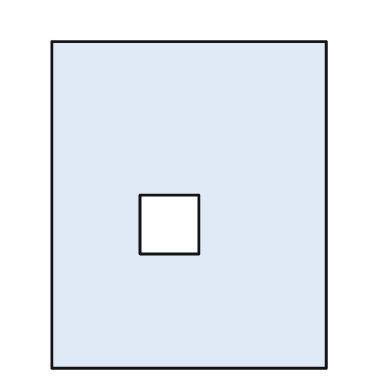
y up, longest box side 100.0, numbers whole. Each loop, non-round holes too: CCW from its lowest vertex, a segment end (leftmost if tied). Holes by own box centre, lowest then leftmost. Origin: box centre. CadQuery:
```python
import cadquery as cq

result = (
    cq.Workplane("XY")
    .moveTo(-42.0, -50.0)
    .lineTo(42.0, -50.0)
    .lineTo(42.0, 50.0)
    .lineTo(-42.0, 50.0)
    .close()
    .moveTo(-15.0, -15.0)
    .lineTo(3.0, -15.0)
    .lineTo(3.0, 3.0)
    .lineTo(-15.0, 3.0)
    .close()
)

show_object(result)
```